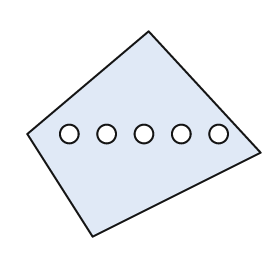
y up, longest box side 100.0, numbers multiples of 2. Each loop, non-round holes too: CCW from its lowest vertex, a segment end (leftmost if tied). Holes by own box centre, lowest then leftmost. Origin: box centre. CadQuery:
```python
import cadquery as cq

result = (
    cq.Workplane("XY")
    .moveTo(-22.0, -44.0)
    .lineTo(50.0, -8.0)
    .lineTo(2.0, 44.0)
    .lineTo(-50.0, 0.0)
    .close()
    .moveTo(-32.0, 0.0)
    .circle(4.0)
    .moveTo(-16.0, 0.0)
    .circle(4.0)
    .moveTo(0.0, 0.0)
    .circle(4.0)
    .moveTo(16.0, 0.0)
    .circle(4.0)
    .moveTo(32.0, 0.0)
    .circle(4.0)
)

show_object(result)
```